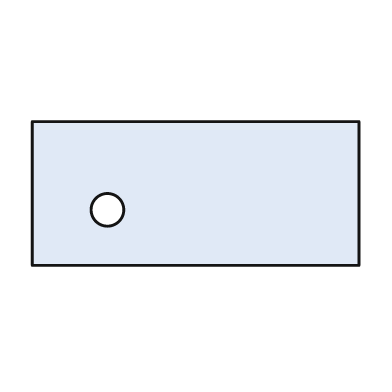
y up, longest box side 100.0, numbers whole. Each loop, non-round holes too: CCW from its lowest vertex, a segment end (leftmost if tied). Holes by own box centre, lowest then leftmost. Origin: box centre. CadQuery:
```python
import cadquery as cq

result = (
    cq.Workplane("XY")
    .moveTo(-50.0, -22.0)
    .lineTo(50.0, -22.0)
    .lineTo(50.0, 22.0)
    .lineTo(-50.0, 22.0)
    .close()
    .moveTo(-27.0, -5.0)
    .circle(5.0)
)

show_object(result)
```